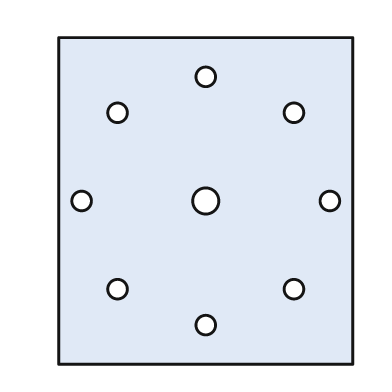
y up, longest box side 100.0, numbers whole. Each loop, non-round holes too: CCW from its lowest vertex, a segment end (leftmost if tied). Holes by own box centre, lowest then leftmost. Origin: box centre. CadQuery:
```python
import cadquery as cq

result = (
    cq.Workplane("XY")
    .moveTo(-45.0, -50.0)
    .lineTo(45.0, -50.0)
    .lineTo(45.0, 50.0)
    .lineTo(-45.0, 50.0)
    .close()
    .moveTo(0.0, -38.0)
    .circle(3.0)
    .moveTo(-27.0, -27.0)
    .circle(3.0)
    .moveTo(27.0, -27.0)
    .circle(3.0)
    .moveTo(-38.0, 0.0)
    .circle(3.0)
    .moveTo(0.0, 0.0)
    .circle(4.0)
    .moveTo(38.0, 0.0)
    .circle(3.0)
    .moveTo(-27.0, 27.0)
    .circle(3.0)
    .moveTo(27.0, 27.0)
    .circle(3.0)
    .moveTo(0.0, 38.0)
    .circle(3.0)
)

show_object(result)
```